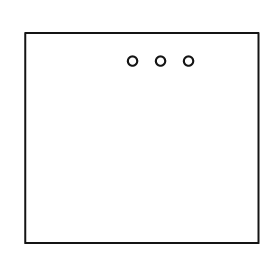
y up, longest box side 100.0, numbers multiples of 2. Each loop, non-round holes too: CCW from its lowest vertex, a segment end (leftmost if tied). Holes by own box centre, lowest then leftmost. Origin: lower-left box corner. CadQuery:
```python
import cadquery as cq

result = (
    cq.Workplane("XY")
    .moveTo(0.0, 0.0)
    .lineTo(100.0, 0.0)
    .lineTo(100.0, 90.0)
    .lineTo(0.0, 90.0)
    .close()
    .moveTo(46.0, 78.0)
    .circle(2.0)
    .moveTo(58.0, 78.0)
    .circle(2.0)
    .moveTo(70.0, 78.0)
    .circle(2.0)
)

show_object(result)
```